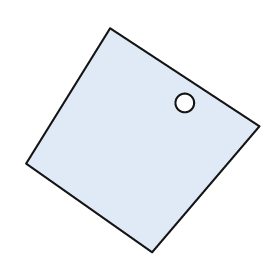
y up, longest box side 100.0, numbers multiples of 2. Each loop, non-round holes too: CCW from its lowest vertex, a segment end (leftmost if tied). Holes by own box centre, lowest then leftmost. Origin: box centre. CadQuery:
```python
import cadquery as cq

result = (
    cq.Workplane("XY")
    .moveTo(4.0, -48.0)
    .lineTo(50.0, 6.0)
    .lineTo(-14.0, 48.0)
    .lineTo(-50.0, -10.0)
    .close()
    .moveTo(18.0, 16.0)
    .circle(4.0)
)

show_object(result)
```